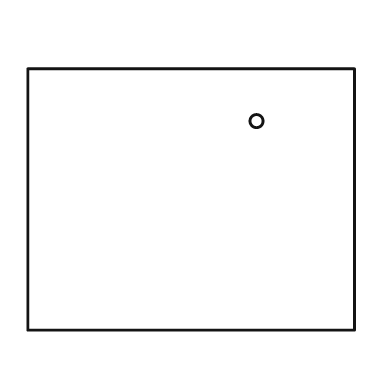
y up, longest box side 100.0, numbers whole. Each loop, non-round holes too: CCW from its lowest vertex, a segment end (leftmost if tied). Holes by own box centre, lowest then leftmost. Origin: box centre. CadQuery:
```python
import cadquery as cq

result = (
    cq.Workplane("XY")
    .moveTo(-50.0, -40.0)
    .lineTo(50.0, -40.0)
    .lineTo(50.0, 40.0)
    .lineTo(-50.0, 40.0)
    .close()
    .moveTo(20.0, 24.0)
    .circle(2.0)
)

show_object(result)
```